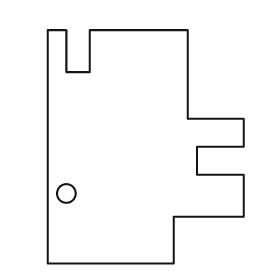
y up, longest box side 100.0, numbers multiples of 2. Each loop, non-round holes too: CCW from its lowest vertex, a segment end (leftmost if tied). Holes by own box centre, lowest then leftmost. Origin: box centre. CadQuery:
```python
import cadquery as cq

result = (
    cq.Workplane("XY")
    .moveTo(-42.0, -50.0)
    .lineTo(12.0, -50.0)
    .lineTo(12.0, -30.0)
    .lineTo(42.0, -30.0)
    .lineTo(42.0, -12.0)
    .lineTo(22.0, -12.0)
    .lineTo(22.0, 0.0)
    .lineTo(42.0, 0.0)
    .lineTo(42.0, 12.0)
    .lineTo(18.0, 12.0)
    .lineTo(18.0, 50.0)
    .lineTo(-24.0, 50.0)
    .lineTo(-24.0, 32.0)
    .lineTo(-34.0, 32.0)
    .lineTo(-34.0, 50.0)
    .lineTo(-42.0, 50.0)
    .close()
    .moveTo(-34.0, -20.0)
    .circle(4.0)
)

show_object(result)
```